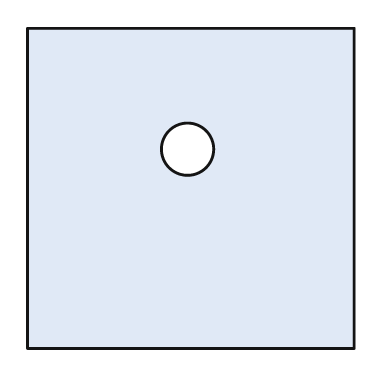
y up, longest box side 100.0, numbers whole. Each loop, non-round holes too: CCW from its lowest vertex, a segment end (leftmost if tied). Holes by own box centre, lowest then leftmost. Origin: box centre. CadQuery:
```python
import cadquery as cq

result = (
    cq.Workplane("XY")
    .moveTo(-50.0, -49.0)
    .lineTo(50.0, -49.0)
    .lineTo(50.0, 49.0)
    .lineTo(-50.0, 49.0)
    .close()
    .moveTo(-1.0, 12.0)
    .circle(8.0)
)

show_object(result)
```